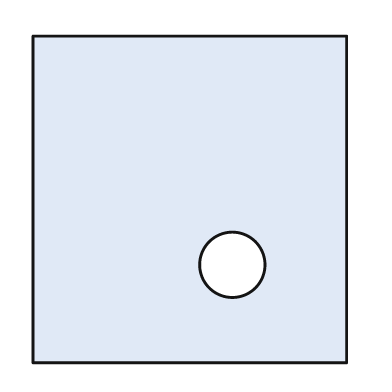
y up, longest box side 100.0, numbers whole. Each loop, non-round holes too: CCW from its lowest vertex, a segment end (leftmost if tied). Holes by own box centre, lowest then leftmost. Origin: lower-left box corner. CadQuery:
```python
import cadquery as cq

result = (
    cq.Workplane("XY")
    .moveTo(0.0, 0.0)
    .lineTo(96.0, 0.0)
    .lineTo(96.0, 100.0)
    .lineTo(0.0, 100.0)
    .close()
    .moveTo(61.0, 30.0)
    .circle(10.0)
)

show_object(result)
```